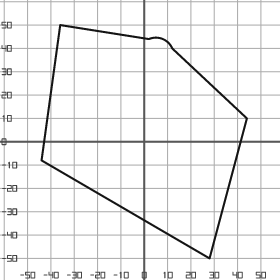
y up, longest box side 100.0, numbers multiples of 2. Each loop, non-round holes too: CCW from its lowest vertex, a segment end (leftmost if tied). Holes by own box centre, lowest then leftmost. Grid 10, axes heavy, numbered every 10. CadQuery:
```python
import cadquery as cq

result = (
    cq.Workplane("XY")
    .moveTo(28.0, -50.0)
    .lineTo(44.0, 10.0)
    .lineTo(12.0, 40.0)
    .threePointArc((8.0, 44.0), (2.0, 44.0))
    .lineTo(-36.0, 50.0)
    .lineTo(-44.0, -8.0)
    .close()
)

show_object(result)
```